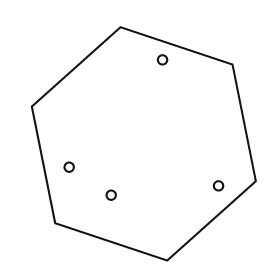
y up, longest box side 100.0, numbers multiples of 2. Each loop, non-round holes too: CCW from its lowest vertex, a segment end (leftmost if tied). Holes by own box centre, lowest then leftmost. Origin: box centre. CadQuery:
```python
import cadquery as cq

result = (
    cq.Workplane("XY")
    .moveTo(10.0, -50.0)
    .lineTo(48.0, -16.0)
    .lineTo(38.0, 34.0)
    .lineTo(-10.0, 50.0)
    .lineTo(-48.0, 16.0)
    .lineTo(-38.0, -34.0)
    .close()
    .moveTo(-14.0, -22.0)
    .circle(2.0)
    .moveTo(32.0, -18.0)
    .circle(2.0)
    .moveTo(-32.0, -10.0)
    .circle(2.0)
    .moveTo(8.0, 36.0)
    .circle(2.0)
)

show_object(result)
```